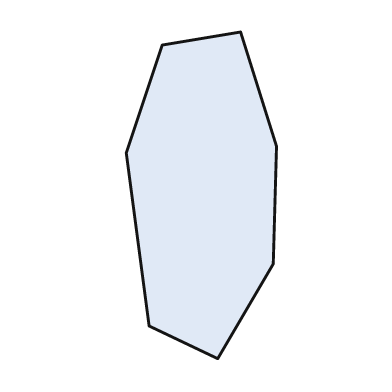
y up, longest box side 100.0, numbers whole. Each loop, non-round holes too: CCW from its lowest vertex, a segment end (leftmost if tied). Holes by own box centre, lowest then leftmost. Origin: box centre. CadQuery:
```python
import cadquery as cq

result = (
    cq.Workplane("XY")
    .moveTo(5.0, -50.0)
    .lineTo(22.0, -21.0)
    .lineTo(23.0, 15.0)
    .lineTo(12.0, 50.0)
    .lineTo(-12.0, 46.0)
    .lineTo(-23.0, 13.0)
    .lineTo(-16.0, -40.0)
    .close()
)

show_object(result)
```